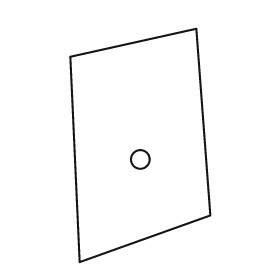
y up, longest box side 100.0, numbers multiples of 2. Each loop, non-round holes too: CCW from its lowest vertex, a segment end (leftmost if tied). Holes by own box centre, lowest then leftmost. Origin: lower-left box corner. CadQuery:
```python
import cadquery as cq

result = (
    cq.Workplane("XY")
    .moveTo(4.0, 0.0)
    .lineTo(60.0, 20.0)
    .lineTo(54.0, 100.0)
    .lineTo(0.0, 88.0)
    .close()
    .moveTo(30.0, 44.0)
    .circle(4.0)
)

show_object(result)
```